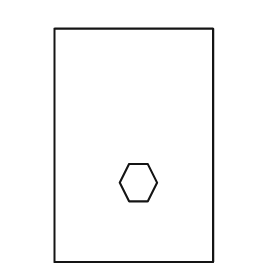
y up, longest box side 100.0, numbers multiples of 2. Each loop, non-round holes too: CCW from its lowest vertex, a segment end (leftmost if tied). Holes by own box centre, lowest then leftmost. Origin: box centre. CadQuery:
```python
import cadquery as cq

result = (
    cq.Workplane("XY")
    .moveTo(-34.0, -50.0)
    .lineTo(34.0, -50.0)
    .lineTo(34.0, 50.0)
    .lineTo(-34.0, 50.0)
    .close()
    .moveTo(-2.0, -24.0)
    .lineTo(6.0, -24.0)
    .lineTo(10.0, -16.0)
    .lineTo(6.0, -8.0)
    .lineTo(-2.0, -8.0)
    .lineTo(-6.0, -16.0)
    .close()
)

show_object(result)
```